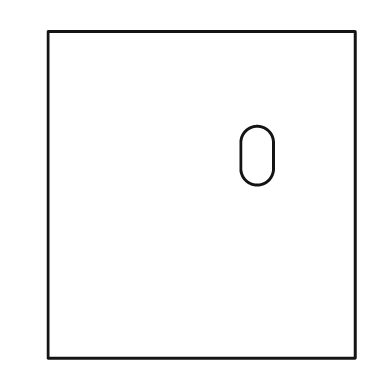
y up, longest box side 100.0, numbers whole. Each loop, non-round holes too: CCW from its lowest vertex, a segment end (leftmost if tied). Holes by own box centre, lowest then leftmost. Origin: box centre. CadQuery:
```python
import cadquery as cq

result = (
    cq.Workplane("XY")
    .moveTo(-47.0, -50.0)
    .lineTo(47.0, -50.0)
    .lineTo(47.0, 50.0)
    .lineTo(-47.0, 50.0)
    .close()
    .moveTo(12.0, 8.0)
    .threePointArc((17.0, 3.0), (22.0, 8.0))
    .lineTo(22.0, 16.0)
    .threePointArc((17.0, 21.0), (12.0, 16.0))
    .close()
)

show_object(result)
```